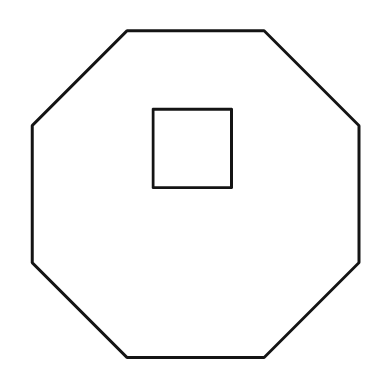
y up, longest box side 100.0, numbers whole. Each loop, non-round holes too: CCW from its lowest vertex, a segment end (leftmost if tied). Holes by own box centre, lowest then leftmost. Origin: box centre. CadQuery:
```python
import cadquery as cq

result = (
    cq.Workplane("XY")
    .moveTo(-21.0, -50.0)
    .lineTo(21.0, -50.0)
    .lineTo(50.0, -21.0)
    .lineTo(50.0, 21.0)
    .lineTo(21.0, 50.0)
    .lineTo(-21.0, 50.0)
    .lineTo(-50.0, 21.0)
    .lineTo(-50.0, -21.0)
    .close()
    .moveTo(-13.0, 2.0)
    .lineTo(11.0, 2.0)
    .lineTo(11.0, 26.0)
    .lineTo(-13.0, 26.0)
    .close()
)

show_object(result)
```